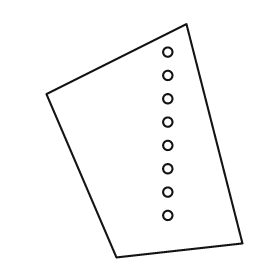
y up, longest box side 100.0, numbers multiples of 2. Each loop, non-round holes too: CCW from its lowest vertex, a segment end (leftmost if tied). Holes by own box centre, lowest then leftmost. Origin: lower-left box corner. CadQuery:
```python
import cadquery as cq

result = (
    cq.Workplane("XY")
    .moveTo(30.0, 0.0)
    .lineTo(84.0, 6.0)
    .lineTo(60.0, 100.0)
    .lineTo(0.0, 70.0)
    .close()
    .moveTo(52.0, 18.0)
    .circle(2.0)
    .moveTo(52.0, 28.0)
    .circle(2.0)
    .moveTo(52.0, 38.0)
    .circle(2.0)
    .moveTo(52.0, 48.0)
    .circle(2.0)
    .moveTo(52.0, 58.0)
    .circle(2.0)
    .moveTo(52.0, 68.0)
    .circle(2.0)
    .moveTo(52.0, 78.0)
    .circle(2.0)
    .moveTo(52.0, 88.0)
    .circle(2.0)
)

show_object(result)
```